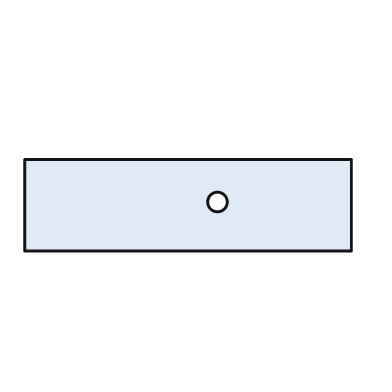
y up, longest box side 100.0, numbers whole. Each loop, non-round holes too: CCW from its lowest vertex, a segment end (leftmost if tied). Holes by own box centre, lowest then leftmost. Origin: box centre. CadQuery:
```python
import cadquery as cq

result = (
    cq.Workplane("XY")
    .moveTo(-50.0, -14.0)
    .lineTo(50.0, -14.0)
    .lineTo(50.0, 14.0)
    .lineTo(-50.0, 14.0)
    .close()
    .moveTo(9.0, 1.0)
    .circle(3.0)
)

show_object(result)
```